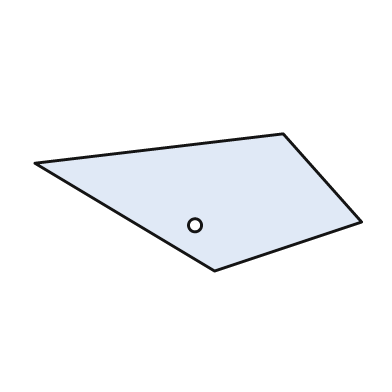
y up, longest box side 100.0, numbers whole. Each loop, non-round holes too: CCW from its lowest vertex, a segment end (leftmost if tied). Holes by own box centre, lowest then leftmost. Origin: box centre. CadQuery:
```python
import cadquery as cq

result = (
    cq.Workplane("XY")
    .moveTo(5.0, -21.0)
    .lineTo(50.0, -6.0)
    .lineTo(26.0, 21.0)
    .lineTo(-50.0, 12.0)
    .close()
    .moveTo(-1.0, -7.0)
    .circle(2.0)
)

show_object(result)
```